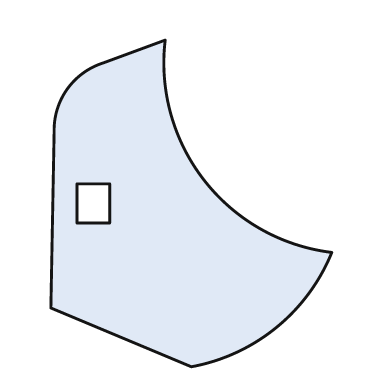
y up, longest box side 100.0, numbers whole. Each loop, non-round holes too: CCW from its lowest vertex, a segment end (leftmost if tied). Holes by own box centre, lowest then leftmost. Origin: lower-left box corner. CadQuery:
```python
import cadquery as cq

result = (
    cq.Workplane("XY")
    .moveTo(43.0, 0.0)
    .threePointArc((69.0, 12.0), (86.0, 35.0))
    .threePointArc((47.0, 57.0), (35.0, 100.0))
    .lineTo(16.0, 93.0)
    .threePointArc((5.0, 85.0), (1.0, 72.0))
    .lineTo(0.0, 18.0)
    .close()
    .moveTo(8.0, 44.0)
    .lineTo(18.0, 44.0)
    .lineTo(18.0, 56.0)
    .lineTo(8.0, 56.0)
    .close()
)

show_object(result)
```